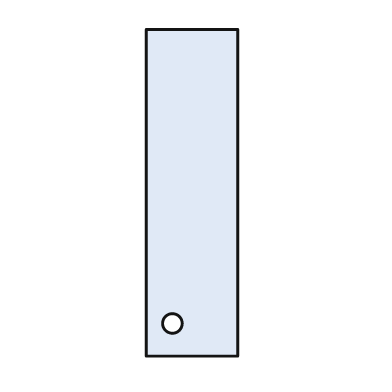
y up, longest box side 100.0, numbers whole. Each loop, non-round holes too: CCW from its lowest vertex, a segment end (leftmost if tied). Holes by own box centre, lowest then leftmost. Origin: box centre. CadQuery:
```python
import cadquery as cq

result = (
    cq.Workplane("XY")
    .moveTo(-14.0, -50.0)
    .lineTo(14.0, -50.0)
    .lineTo(14.0, 50.0)
    .lineTo(-14.0, 50.0)
    .close()
    .moveTo(-6.0, -40.0)
    .circle(3.0)
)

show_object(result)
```